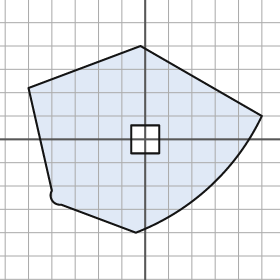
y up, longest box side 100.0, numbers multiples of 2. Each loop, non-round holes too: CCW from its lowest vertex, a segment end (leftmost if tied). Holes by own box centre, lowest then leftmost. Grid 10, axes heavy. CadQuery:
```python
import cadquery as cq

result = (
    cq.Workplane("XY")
    .moveTo(-4.0, -40.0)
    .threePointArc((28.0, -20.0), (50.0, 10.0))
    .lineTo(-2.0, 40.0)
    .lineTo(-50.0, 22.0)
    .lineTo(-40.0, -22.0)
    .threePointArc((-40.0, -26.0), (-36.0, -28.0))
    .close()
    .moveTo(-6.0, -6.0)
    .lineTo(6.0, -6.0)
    .lineTo(6.0, 6.0)
    .lineTo(-6.0, 6.0)
    .close()
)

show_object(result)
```